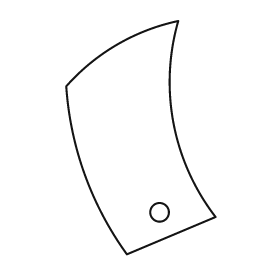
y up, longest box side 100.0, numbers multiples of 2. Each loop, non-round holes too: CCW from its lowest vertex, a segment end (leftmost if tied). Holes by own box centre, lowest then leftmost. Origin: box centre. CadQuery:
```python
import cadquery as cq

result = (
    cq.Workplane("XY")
    .moveTo(-6.0, -50.0)
    .lineTo(32.0, -34.0)
    .threePointArc((14.0, 6.0), (16.0, 50.0))
    .threePointArc((-10.0, 40.0), (-32.0, 22.0))
    .threePointArc((-24.0, -16.0), (-6.0, -50.0))
    .close()
    .moveTo(8.0, -32.0)
    .circle(4.0)
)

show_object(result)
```